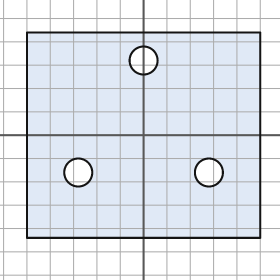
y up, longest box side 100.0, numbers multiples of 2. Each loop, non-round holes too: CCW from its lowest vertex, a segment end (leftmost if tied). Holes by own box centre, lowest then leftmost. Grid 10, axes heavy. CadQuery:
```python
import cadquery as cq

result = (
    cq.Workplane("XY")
    .moveTo(-50.0, -44.0)
    .lineTo(50.0, -44.0)
    .lineTo(50.0, 44.0)
    .lineTo(-50.0, 44.0)
    .close()
    .moveTo(-28.0, -16.0)
    .circle(6.0)
    .moveTo(28.0, -16.0)
    .circle(6.0)
    .moveTo(0.0, 32.0)
    .circle(6.0)
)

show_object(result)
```